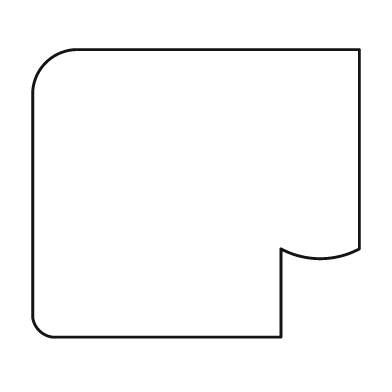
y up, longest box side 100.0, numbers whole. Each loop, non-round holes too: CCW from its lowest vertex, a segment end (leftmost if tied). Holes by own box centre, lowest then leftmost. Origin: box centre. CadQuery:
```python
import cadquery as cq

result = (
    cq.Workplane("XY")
    .moveTo(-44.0, -44.0)
    .lineTo(26.0, -44.0)
    .lineTo(26.0, -17.0)
    .threePointArc((38.0, -20.0), (50.0, -17.0))
    .lineTo(50.0, 44.0)
    .lineTo(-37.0, 44.0)
    .threePointArc((-46.0, 40.0), (-50.0, 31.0))
    .lineTo(-50.0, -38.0)
    .threePointArc((-48.0, -42.0), (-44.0, -44.0))
    .close()
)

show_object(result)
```